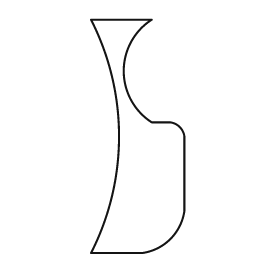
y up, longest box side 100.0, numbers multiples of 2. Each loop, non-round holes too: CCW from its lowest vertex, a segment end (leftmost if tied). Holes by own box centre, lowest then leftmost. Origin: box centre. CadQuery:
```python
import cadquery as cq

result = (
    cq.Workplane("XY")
    .moveTo(-20.0, -50.0)
    .lineTo(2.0, -50.0)
    .threePointArc((14.0, -44.0), (20.0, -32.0))
    .lineTo(20.0, 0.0)
    .threePointArc((18.0, 4.0), (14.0, 6.0))
    .lineTo(6.0, 6.0)
    .threePointArc((-6.0, 28.0), (6.0, 50.0))
    .lineTo(-20.0, 50.0)
    .threePointArc((-8.0, 0.0), (-20.0, -50.0))
    .close()
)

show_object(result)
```